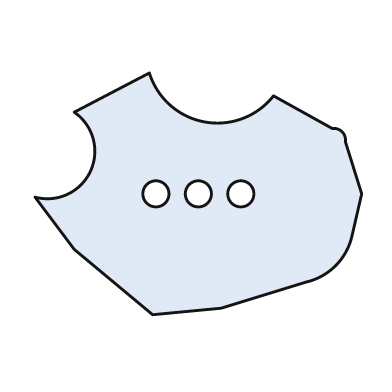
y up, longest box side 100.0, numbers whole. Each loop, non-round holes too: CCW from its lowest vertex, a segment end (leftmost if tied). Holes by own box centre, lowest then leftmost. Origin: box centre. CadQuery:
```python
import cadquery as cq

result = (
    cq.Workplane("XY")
    .moveTo(-14.0, -37.0)
    .lineTo(7.0, -35.0)
    .lineTo(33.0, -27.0)
    .threePointArc((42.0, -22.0), (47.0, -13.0))
    .lineTo(50.0, 0.0)
    .lineTo(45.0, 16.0)
    .threePointArc((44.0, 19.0), (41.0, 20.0))
    .lineTo(23.0, 30.0)
    .threePointArc((2.0, 22.0), (-15.0, 37.0))
    .lineTo(-38.0, 25.0)
    .threePointArc((-33.0, 7.0), (-50.0, -1.0))
    .lineTo(-38.0, -17.0)
    .close()
    .moveTo(-13.0, 0.0)
    .circle(4.0)
    .moveTo(0.0, 0.0)
    .circle(4.0)
    .moveTo(13.0, 0.0)
    .circle(4.0)
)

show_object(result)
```